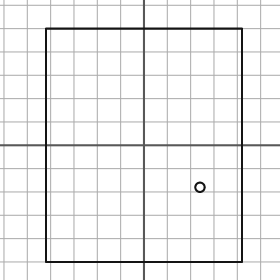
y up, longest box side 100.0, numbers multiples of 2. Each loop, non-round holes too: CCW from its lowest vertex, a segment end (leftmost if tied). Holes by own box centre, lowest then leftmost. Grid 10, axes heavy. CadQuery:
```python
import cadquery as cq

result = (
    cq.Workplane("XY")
    .moveTo(-42.0, -50.0)
    .lineTo(42.0, -50.0)
    .lineTo(42.0, 50.0)
    .lineTo(-42.0, 50.0)
    .close()
    .moveTo(24.0, -18.0)
    .circle(2.0)
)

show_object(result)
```